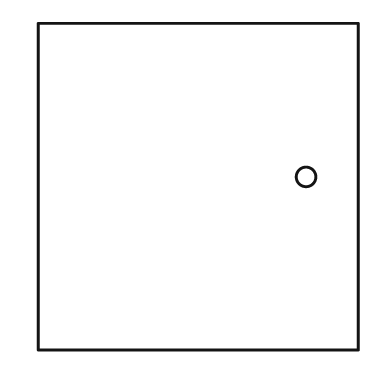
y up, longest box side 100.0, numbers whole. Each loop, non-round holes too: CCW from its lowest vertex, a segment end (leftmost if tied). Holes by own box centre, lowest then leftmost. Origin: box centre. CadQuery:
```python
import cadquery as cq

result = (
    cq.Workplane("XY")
    .moveTo(-49.0, -50.0)
    .lineTo(49.0, -50.0)
    .lineTo(49.0, 50.0)
    .lineTo(-49.0, 50.0)
    .close()
    .moveTo(33.0, 3.0)
    .circle(3.0)
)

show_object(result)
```